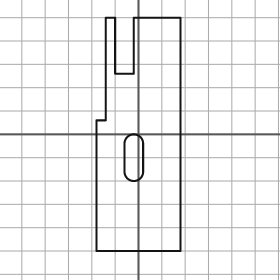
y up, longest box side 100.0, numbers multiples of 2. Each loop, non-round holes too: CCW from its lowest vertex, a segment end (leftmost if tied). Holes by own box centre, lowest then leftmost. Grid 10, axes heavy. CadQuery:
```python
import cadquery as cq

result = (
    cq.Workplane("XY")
    .moveTo(-18.0, -50.0)
    .lineTo(18.0, -50.0)
    .lineTo(18.0, 50.0)
    .lineTo(-2.0, 50.0)
    .lineTo(-2.0, 26.0)
    .lineTo(-10.0, 26.0)
    .lineTo(-10.0, 50.0)
    .lineTo(-14.0, 50.0)
    .lineTo(-14.0, 6.0)
    .lineTo(-18.0, 6.0)
    .close()
    .moveTo(-6.0, -16.0)
    .threePointArc((-2.0, -20.0), (2.0, -16.0))
    .lineTo(2.0, -4.0)
    .threePointArc((-2.0, 0.0), (-6.0, -4.0))
    .close()
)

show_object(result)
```